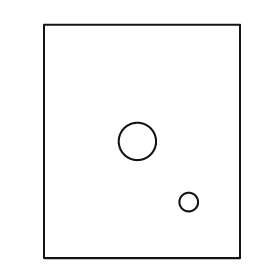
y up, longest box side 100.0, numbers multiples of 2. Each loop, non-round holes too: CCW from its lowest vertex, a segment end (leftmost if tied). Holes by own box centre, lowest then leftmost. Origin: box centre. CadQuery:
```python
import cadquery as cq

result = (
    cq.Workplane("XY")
    .moveTo(-42.0, -50.0)
    .lineTo(42.0, -50.0)
    .lineTo(42.0, 50.0)
    .lineTo(-42.0, 50.0)
    .close()
    .moveTo(20.0, -26.0)
    .circle(4.0)
    .moveTo(-2.0, 0.0)
    .circle(8.0)
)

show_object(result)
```